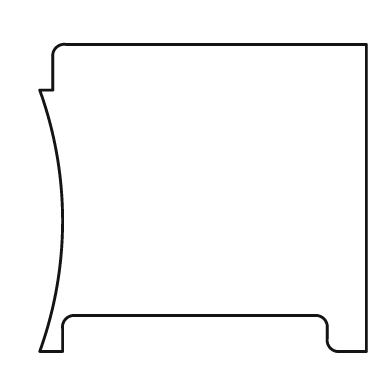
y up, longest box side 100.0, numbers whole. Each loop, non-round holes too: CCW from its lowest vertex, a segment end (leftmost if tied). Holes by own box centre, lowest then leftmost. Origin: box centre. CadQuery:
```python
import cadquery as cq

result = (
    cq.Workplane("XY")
    .moveTo(-50.0, -47.0)
    .lineTo(-43.0, -47.0)
    .lineTo(-43.0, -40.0)
    .threePointArc((-42.0, -37.0), (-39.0, -36.0))
    .lineTo(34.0, -36.0)
    .threePointArc((37.0, -37.0), (38.0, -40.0))
    .lineTo(38.0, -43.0)
    .threePointArc((39.0, -46.0), (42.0, -47.0))
    .lineTo(50.0, -47.0)
    .lineTo(50.0, 47.0)
    .lineTo(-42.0, 47.0)
    .threePointArc((-45.0, 46.0), (-46.0, 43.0))
    .lineTo(-46.0, 33.0)
    .lineTo(-50.0, 33.0)
    .threePointArc((-43.0, -7.0), (-50.0, -47.0))
    .close()
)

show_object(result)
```